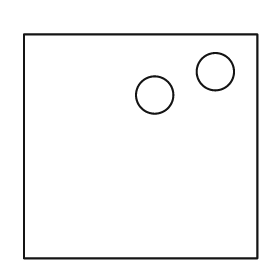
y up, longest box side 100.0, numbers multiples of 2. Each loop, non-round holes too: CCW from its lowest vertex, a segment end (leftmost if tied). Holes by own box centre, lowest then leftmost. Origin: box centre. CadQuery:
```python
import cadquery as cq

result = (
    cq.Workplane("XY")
    .moveTo(-50.0, -48.0)
    .lineTo(50.0, -48.0)
    .lineTo(50.0, 48.0)
    .lineTo(-50.0, 48.0)
    .close()
    .moveTo(6.0, 22.0)
    .circle(8.0)
    .moveTo(32.0, 32.0)
    .circle(8.0)
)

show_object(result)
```